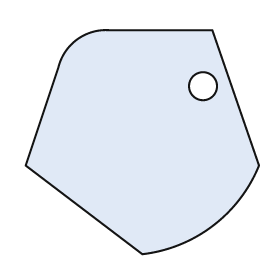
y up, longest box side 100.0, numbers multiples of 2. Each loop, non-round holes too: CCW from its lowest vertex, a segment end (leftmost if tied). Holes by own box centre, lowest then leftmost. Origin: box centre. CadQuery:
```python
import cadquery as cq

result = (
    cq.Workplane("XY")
    .moveTo(0.0, -48.0)
    .threePointArc((30.0, -36.0), (50.0, -10.0))
    .lineTo(30.0, 48.0)
    .lineTo(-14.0, 48.0)
    .threePointArc((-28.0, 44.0), (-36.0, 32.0))
    .lineTo(-50.0, -10.0)
    .close()
    .moveTo(26.0, 24.0)
    .circle(6.0)
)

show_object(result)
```